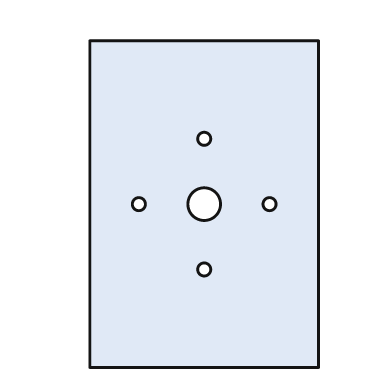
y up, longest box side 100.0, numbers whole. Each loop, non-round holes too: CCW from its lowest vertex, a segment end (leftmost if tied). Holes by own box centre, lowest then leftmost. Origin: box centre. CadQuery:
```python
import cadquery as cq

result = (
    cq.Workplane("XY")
    .moveTo(-35.0, -50.0)
    .lineTo(35.0, -50.0)
    .lineTo(35.0, 50.0)
    .lineTo(-35.0, 50.0)
    .close()
    .moveTo(0.0, -20.0)
    .circle(2.0)
    .moveTo(-20.0, 0.0)
    .circle(2.0)
    .moveTo(0.0, 0.0)
    .circle(5.0)
    .moveTo(20.0, 0.0)
    .circle(2.0)
    .moveTo(0.0, 20.0)
    .circle(2.0)
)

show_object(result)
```